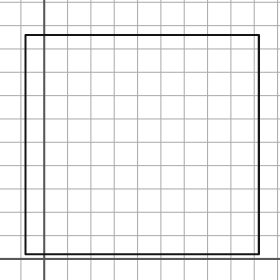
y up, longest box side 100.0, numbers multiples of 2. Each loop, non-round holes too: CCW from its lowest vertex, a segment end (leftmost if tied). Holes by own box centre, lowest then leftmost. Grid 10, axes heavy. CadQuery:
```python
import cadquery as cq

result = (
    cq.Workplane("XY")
    .moveTo(-8.0, 2.0)
    .lineTo(92.0, 2.0)
    .lineTo(92.0, 96.0)
    .lineTo(-8.0, 96.0)
    .close()
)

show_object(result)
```